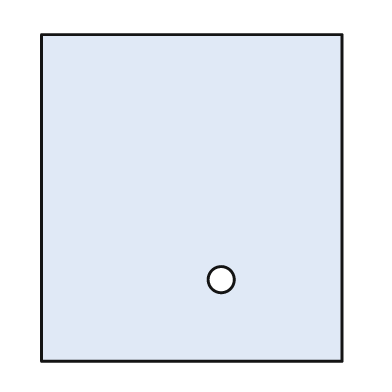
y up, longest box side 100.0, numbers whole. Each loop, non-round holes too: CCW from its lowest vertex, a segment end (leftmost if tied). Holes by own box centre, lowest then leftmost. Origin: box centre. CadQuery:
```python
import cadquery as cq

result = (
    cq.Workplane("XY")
    .moveTo(-46.0, -50.0)
    .lineTo(46.0, -50.0)
    .lineTo(46.0, 50.0)
    .lineTo(-46.0, 50.0)
    .close()
    .moveTo(9.0, -25.0)
    .circle(4.0)
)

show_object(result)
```